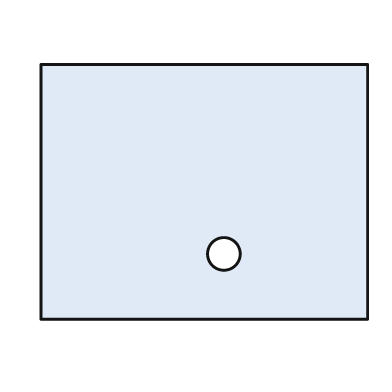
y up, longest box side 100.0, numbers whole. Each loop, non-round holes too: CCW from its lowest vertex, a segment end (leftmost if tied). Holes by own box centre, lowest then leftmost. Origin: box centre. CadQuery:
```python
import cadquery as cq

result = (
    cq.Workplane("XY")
    .moveTo(-50.0, -39.0)
    .lineTo(50.0, -39.0)
    .lineTo(50.0, 39.0)
    .lineTo(-50.0, 39.0)
    .close()
    .moveTo(6.0, -19.0)
    .circle(5.0)
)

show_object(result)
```